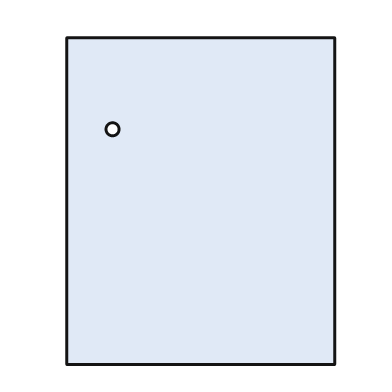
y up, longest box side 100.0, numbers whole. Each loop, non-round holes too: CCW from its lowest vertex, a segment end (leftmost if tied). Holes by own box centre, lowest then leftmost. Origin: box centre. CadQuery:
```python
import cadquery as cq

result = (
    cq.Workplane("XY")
    .moveTo(-41.0, -50.0)
    .lineTo(41.0, -50.0)
    .lineTo(41.0, 50.0)
    .lineTo(-41.0, 50.0)
    .close()
    .moveTo(-27.0, 22.0)
    .circle(2.0)
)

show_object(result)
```